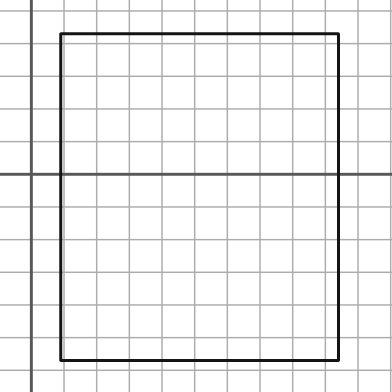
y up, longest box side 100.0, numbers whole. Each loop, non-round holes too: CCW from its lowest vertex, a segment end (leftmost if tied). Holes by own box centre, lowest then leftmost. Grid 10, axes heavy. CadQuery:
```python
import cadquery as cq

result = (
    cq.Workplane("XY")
    .moveTo(9.0, -57.0)
    .lineTo(94.0, -57.0)
    .lineTo(94.0, 43.0)
    .lineTo(9.0, 43.0)
    .close()
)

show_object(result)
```